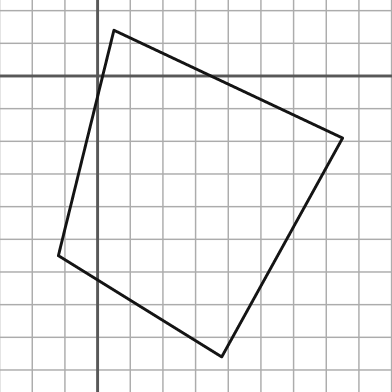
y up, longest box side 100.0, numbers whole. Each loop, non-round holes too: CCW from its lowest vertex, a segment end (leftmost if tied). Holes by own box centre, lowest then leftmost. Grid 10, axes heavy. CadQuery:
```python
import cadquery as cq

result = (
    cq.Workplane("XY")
    .moveTo(38.0, -86.0)
    .lineTo(75.0, -19.0)
    .lineTo(5.0, 14.0)
    .lineTo(-12.0, -55.0)
    .close()
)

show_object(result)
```